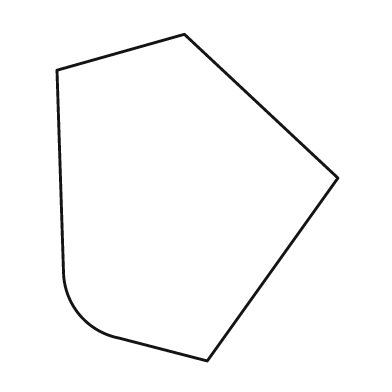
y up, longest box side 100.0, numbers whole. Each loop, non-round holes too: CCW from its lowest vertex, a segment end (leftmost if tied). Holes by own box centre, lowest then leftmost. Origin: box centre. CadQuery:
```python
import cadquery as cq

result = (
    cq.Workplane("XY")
    .moveTo(3.0, -50.0)
    .lineTo(43.0, 6.0)
    .lineTo(-4.0, 50.0)
    .lineTo(-43.0, 39.0)
    .lineTo(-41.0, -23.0)
    .threePointArc((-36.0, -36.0), (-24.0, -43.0))
    .close()
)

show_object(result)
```